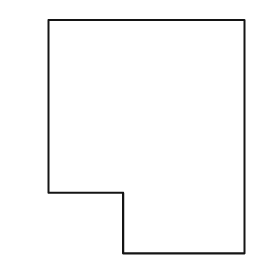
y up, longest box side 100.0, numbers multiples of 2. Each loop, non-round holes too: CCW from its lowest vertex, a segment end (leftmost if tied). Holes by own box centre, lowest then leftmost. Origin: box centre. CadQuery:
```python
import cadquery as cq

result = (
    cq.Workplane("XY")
    .moveTo(-10.0, -50.0)
    .lineTo(42.0, -50.0)
    .lineTo(42.0, 50.0)
    .lineTo(-42.0, 50.0)
    .lineTo(-42.0, -24.0)
    .lineTo(-10.0, -24.0)
    .close()
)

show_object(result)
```